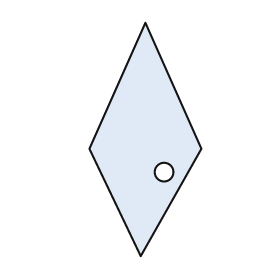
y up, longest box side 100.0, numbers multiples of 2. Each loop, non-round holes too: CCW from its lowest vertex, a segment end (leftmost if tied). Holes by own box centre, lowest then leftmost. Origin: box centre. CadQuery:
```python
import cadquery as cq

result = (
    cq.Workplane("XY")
    .moveTo(-2.0, -50.0)
    .lineTo(24.0, -4.0)
    .lineTo(0.0, 50.0)
    .lineTo(-24.0, -4.0)
    .close()
    .moveTo(8.0, -14.0)
    .circle(4.0)
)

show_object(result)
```